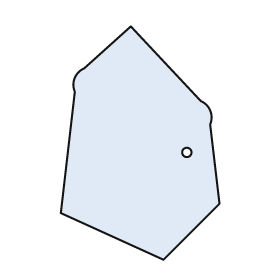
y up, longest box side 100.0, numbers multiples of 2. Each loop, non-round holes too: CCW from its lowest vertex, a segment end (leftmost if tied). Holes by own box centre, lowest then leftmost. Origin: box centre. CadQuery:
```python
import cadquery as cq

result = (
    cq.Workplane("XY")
    .moveTo(10.0, -50.0)
    .lineTo(34.0, -26.0)
    .lineTo(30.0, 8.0)
    .threePointArc((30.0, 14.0), (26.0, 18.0))
    .lineTo(-4.0, 50.0)
    .lineTo(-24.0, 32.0)
    .threePointArc((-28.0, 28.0), (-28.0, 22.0))
    .lineTo(-34.0, -30.0)
    .close()
    .moveTo(20.0, -4.0)
    .circle(2.0)
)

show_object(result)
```